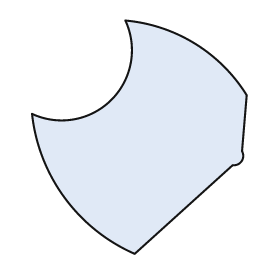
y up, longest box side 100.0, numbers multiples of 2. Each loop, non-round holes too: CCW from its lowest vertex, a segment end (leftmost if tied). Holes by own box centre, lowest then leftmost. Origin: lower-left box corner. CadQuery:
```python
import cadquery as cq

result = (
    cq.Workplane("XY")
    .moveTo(44.0, 0.0)
    .lineTo(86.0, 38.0)
    .threePointArc((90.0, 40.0), (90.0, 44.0))
    .lineTo(92.0, 68.0)
    .threePointArc((70.0, 90.0), (40.0, 100.0))
    .threePointArc((34.0, 66.0), (0.0, 60.0))
    .threePointArc((14.0, 24.0), (44.0, 0.0))
    .close()
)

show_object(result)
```